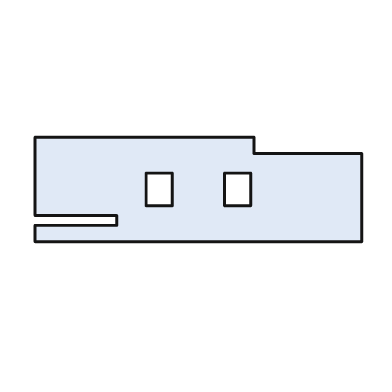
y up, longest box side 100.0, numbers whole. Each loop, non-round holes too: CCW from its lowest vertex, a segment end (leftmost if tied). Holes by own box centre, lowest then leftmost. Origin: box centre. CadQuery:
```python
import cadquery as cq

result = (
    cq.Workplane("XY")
    .moveTo(-50.0, -16.0)
    .lineTo(50.0, -16.0)
    .lineTo(50.0, 11.0)
    .lineTo(17.0, 11.0)
    .lineTo(17.0, 16.0)
    .lineTo(-50.0, 16.0)
    .lineTo(-50.0, -8.0)
    .lineTo(-25.0, -8.0)
    .lineTo(-25.0, -11.0)
    .lineTo(-50.0, -11.0)
    .close()
    .moveTo(-16.0, -5.0)
    .lineTo(-8.0, -5.0)
    .lineTo(-8.0, 5.0)
    .lineTo(-16.0, 5.0)
    .close()
    .moveTo(8.0, -5.0)
    .lineTo(16.0, -5.0)
    .lineTo(16.0, 5.0)
    .lineTo(8.0, 5.0)
    .close()
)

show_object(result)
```